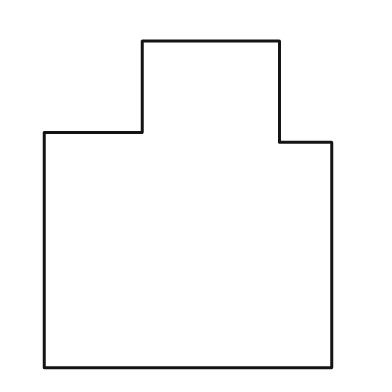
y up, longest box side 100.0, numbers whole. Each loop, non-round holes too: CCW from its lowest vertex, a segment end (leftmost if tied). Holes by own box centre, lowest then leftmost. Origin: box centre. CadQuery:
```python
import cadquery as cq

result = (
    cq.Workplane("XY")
    .moveTo(-44.0, -50.0)
    .lineTo(44.0, -50.0)
    .lineTo(44.0, 19.0)
    .lineTo(28.0, 19.0)
    .lineTo(28.0, 50.0)
    .lineTo(-14.0, 50.0)
    .lineTo(-14.0, 22.0)
    .lineTo(-44.0, 22.0)
    .close()
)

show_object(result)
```